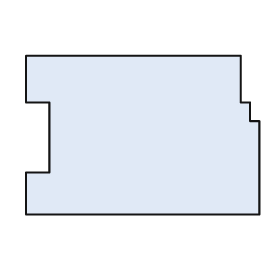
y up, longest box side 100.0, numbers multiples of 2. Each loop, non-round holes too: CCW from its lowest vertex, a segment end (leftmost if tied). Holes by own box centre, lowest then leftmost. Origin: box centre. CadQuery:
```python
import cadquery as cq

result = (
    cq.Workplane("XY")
    .moveTo(-50.0, -34.0)
    .lineTo(50.0, -34.0)
    .lineTo(50.0, 6.0)
    .lineTo(46.0, 6.0)
    .lineTo(46.0, 14.0)
    .lineTo(42.0, 14.0)
    .lineTo(42.0, 34.0)
    .lineTo(-50.0, 34.0)
    .lineTo(-50.0, 14.0)
    .lineTo(-40.0, 14.0)
    .lineTo(-40.0, -16.0)
    .lineTo(-50.0, -16.0)
    .close()
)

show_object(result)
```